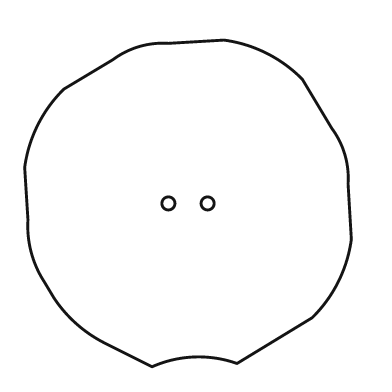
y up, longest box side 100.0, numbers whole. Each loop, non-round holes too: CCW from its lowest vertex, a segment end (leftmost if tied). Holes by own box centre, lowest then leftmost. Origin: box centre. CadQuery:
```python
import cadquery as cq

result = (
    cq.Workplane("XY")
    .moveTo(-11.0, -50.0)
    .threePointArc((2.0, -47.0), (15.0, -49.0))
    .lineTo(38.0, -35.0)
    .threePointArc((46.0, -24.0), (50.0, -11.0))
    .lineTo(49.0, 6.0)
    .threePointArc((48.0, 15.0), (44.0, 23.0))
    .lineTo(35.0, 38.0)
    .threePointArc((24.0, 46.0), (11.0, 50.0))
    .lineTo(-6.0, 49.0)
    .threePointArc((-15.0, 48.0), (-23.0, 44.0))
    .lineTo(-38.0, 35.0)
    .threePointArc((-46.0, 24.0), (-50.0, 11.0))
    .lineTo(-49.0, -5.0)
    .threePointArc((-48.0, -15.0), (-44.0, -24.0))
    .lineTo(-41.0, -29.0)
    .threePointArc((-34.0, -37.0), (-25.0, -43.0))
    .close()
    .moveTo(-6.0, 0.0)
    .circle(2.0)
    .moveTo(6.0, 0.0)
    .circle(2.0)
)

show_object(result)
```